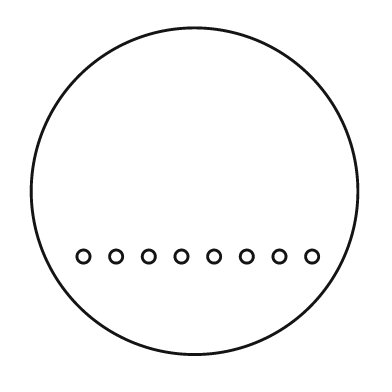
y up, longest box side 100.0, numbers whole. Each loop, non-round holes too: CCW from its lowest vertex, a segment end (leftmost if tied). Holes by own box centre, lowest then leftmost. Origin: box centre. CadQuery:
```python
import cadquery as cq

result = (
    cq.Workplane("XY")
    .moveTo(0.0, 0.0)
    .circle(50.0)
    .moveTo(-34.0, -20.0)
    .circle(2.0)
    .moveTo(-24.0, -20.0)
    .circle(2.0)
    .moveTo(-14.0, -20.0)
    .circle(2.0)
    .moveTo(-4.0, -20.0)
    .circle(2.0)
    .moveTo(6.0, -20.0)
    .circle(2.0)
    .moveTo(16.0, -20.0)
    .circle(2.0)
    .moveTo(26.0, -20.0)
    .circle(2.0)
    .moveTo(36.0, -20.0)
    .circle(2.0)
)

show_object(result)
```